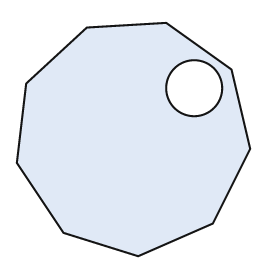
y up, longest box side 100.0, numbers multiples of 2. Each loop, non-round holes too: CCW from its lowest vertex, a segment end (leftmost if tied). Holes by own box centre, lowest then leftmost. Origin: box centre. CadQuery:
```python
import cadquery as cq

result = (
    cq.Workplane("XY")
    .moveTo(2.0, -50.0)
    .lineTo(34.0, -36.0)
    .lineTo(50.0, -4.0)
    .lineTo(42.0, 30.0)
    .lineTo(14.0, 50.0)
    .lineTo(-20.0, 48.0)
    .lineTo(-46.0, 24.0)
    .lineTo(-50.0, -10.0)
    .lineTo(-30.0, -40.0)
    .close()
    .moveTo(26.0, 22.0)
    .circle(12.0)
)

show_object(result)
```